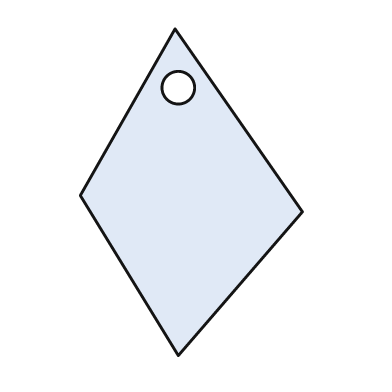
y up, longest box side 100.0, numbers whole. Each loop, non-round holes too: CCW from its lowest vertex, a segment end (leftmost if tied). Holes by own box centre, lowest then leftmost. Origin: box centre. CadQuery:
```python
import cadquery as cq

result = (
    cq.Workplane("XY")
    .moveTo(-4.0, -50.0)
    .lineTo(34.0, -6.0)
    .lineTo(-5.0, 50.0)
    .lineTo(-34.0, -1.0)
    .close()
    .moveTo(-4.0, 32.0)
    .circle(5.0)
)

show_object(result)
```